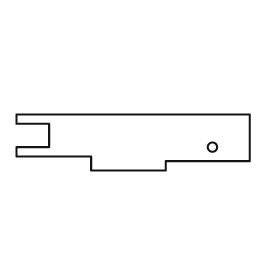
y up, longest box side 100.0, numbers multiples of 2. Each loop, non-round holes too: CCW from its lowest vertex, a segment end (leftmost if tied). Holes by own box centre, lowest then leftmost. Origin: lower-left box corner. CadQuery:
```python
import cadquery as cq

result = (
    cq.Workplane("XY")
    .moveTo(32.0, 0.0)
    .lineTo(64.0, 0.0)
    .lineTo(64.0, 4.0)
    .lineTo(100.0, 4.0)
    .lineTo(100.0, 24.0)
    .lineTo(0.0, 24.0)
    .lineTo(0.0, 20.0)
    .lineTo(14.0, 20.0)
    .lineTo(14.0, 10.0)
    .lineTo(0.0, 10.0)
    .lineTo(0.0, 6.0)
    .lineTo(32.0, 6.0)
    .close()
    .moveTo(84.0, 10.0)
    .circle(2.0)
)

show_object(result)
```